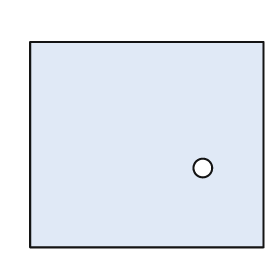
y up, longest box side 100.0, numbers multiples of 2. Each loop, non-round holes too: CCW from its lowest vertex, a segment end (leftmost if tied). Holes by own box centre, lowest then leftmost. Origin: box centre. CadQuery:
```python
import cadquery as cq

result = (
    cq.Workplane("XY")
    .moveTo(-50.0, -44.0)
    .lineTo(50.0, -44.0)
    .lineTo(50.0, 44.0)
    .lineTo(-50.0, 44.0)
    .close()
    .moveTo(24.0, -10.0)
    .circle(4.0)
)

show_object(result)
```